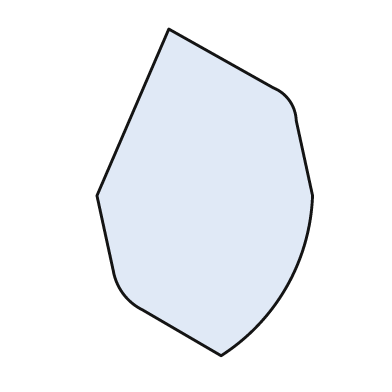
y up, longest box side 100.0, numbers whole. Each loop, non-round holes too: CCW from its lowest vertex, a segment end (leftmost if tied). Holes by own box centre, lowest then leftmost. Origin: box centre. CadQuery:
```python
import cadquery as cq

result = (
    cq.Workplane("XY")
    .moveTo(5.0, -50.0)
    .threePointArc((25.0, -29.0), (33.0, -1.0))
    .lineTo(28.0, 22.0)
    .threePointArc((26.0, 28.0), (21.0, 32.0))
    .lineTo(-11.0, 50.0)
    .lineTo(-33.0, -1.0)
    .lineTo(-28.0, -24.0)
    .threePointArc((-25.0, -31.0), (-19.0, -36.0))
    .close()
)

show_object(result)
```